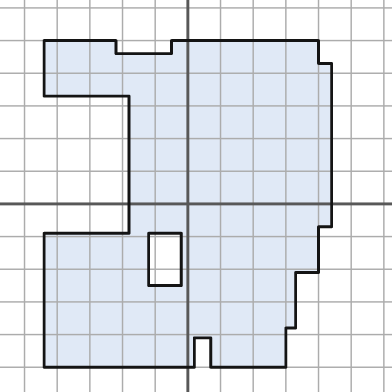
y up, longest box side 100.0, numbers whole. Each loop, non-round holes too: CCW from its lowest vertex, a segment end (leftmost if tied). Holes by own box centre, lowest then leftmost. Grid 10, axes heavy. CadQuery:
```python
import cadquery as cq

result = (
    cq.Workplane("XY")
    .moveTo(-44.0, -50.0)
    .lineTo(2.0, -50.0)
    .lineTo(2.0, -41.0)
    .lineTo(7.0, -41.0)
    .lineTo(7.0, -50.0)
    .lineTo(30.0, -50.0)
    .lineTo(30.0, -38.0)
    .lineTo(33.0, -38.0)
    .lineTo(33.0, -21.0)
    .lineTo(40.0, -21.0)
    .lineTo(40.0, -7.0)
    .lineTo(44.0, -7.0)
    .lineTo(44.0, 43.0)
    .lineTo(40.0, 43.0)
    .lineTo(40.0, 50.0)
    .lineTo(-5.0, 50.0)
    .lineTo(-5.0, 46.0)
    .lineTo(-22.0, 46.0)
    .lineTo(-22.0, 50.0)
    .lineTo(-44.0, 50.0)
    .lineTo(-44.0, 33.0)
    .lineTo(-18.0, 33.0)
    .lineTo(-18.0, -9.0)
    .lineTo(-44.0, -9.0)
    .close()
    .moveTo(-12.0, -25.0)
    .lineTo(-2.0, -25.0)
    .lineTo(-2.0, -9.0)
    .lineTo(-12.0, -9.0)
    .close()
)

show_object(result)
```